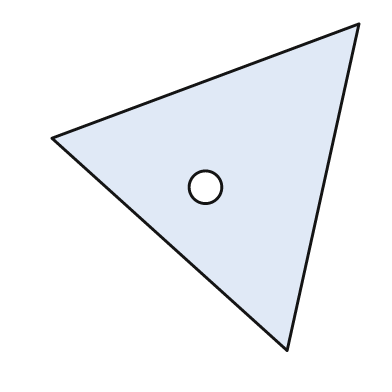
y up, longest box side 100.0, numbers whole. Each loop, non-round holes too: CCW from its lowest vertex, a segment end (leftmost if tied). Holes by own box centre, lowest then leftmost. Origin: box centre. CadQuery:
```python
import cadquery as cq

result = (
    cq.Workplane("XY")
    .moveTo(25.0, -50.0)
    .lineTo(47.0, 50.0)
    .lineTo(-47.0, 15.0)
    .close()
    .moveTo(0.0, 0.0)
    .circle(5.0)
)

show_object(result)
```